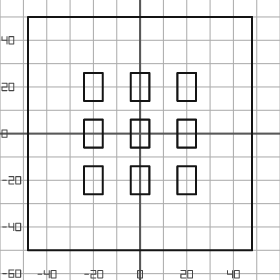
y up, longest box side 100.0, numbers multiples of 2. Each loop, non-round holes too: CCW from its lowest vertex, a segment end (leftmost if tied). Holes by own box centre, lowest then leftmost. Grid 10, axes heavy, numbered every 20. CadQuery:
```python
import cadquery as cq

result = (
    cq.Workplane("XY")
    .moveTo(-48.0, -50.0)
    .lineTo(48.0, -50.0)
    .lineTo(48.0, 50.0)
    .lineTo(-48.0, 50.0)
    .close()
    .moveTo(-24.0, -26.0)
    .lineTo(-16.0, -26.0)
    .lineTo(-16.0, -14.0)
    .lineTo(-24.0, -14.0)
    .close()
    .moveTo(-4.0, -26.0)
    .lineTo(4.0, -26.0)
    .lineTo(4.0, -14.0)
    .lineTo(-4.0, -14.0)
    .close()
    .moveTo(16.0, -26.0)
    .lineTo(24.0, -26.0)
    .lineTo(24.0, -14.0)
    .lineTo(16.0, -14.0)
    .close()
    .moveTo(-24.0, -6.0)
    .lineTo(-16.0, -6.0)
    .lineTo(-16.0, 6.0)
    .lineTo(-24.0, 6.0)
    .close()
    .moveTo(-4.0, -6.0)
    .lineTo(4.0, -6.0)
    .lineTo(4.0, 6.0)
    .lineTo(-4.0, 6.0)
    .close()
    .moveTo(16.0, -6.0)
    .lineTo(24.0, -6.0)
    .lineTo(24.0, 6.0)
    .lineTo(16.0, 6.0)
    .close()
    .moveTo(-24.0, 14.0)
    .lineTo(-16.0, 14.0)
    .lineTo(-16.0, 26.0)
    .lineTo(-24.0, 26.0)
    .close()
    .moveTo(-4.0, 14.0)
    .lineTo(4.0, 14.0)
    .lineTo(4.0, 26.0)
    .lineTo(-4.0, 26.0)
    .close()
    .moveTo(16.0, 14.0)
    .lineTo(24.0, 14.0)
    .lineTo(24.0, 26.0)
    .lineTo(16.0, 26.0)
    .close()
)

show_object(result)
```